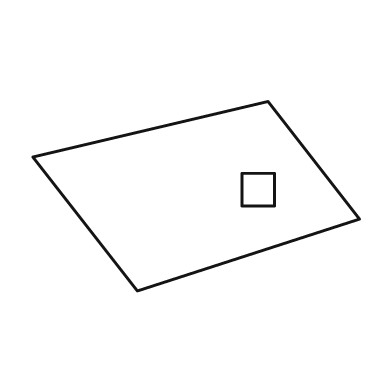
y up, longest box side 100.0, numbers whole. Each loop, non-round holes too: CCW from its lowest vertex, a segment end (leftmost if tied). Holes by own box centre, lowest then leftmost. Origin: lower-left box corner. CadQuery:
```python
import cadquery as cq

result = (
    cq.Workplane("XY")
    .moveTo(32.0, 0.0)
    .lineTo(100.0, 22.0)
    .lineTo(72.0, 58.0)
    .lineTo(0.0, 41.0)
    .close()
    .moveTo(64.0, 26.0)
    .lineTo(74.0, 26.0)
    .lineTo(74.0, 36.0)
    .lineTo(64.0, 36.0)
    .close()
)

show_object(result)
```